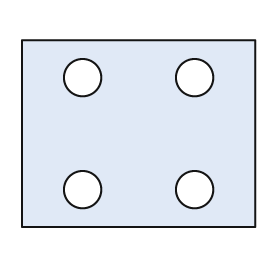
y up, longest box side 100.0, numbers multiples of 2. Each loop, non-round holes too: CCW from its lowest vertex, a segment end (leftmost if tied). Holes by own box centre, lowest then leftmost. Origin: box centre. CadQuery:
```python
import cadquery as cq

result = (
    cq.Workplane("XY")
    .moveTo(-50.0, -40.0)
    .lineTo(50.0, -40.0)
    .lineTo(50.0, 40.0)
    .lineTo(-50.0, 40.0)
    .close()
    .moveTo(-24.0, -24.0)
    .circle(8.0)
    .moveTo(24.0, -24.0)
    .circle(8.0)
    .moveTo(-24.0, 24.0)
    .circle(8.0)
    .moveTo(24.0, 24.0)
    .circle(8.0)
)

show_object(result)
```